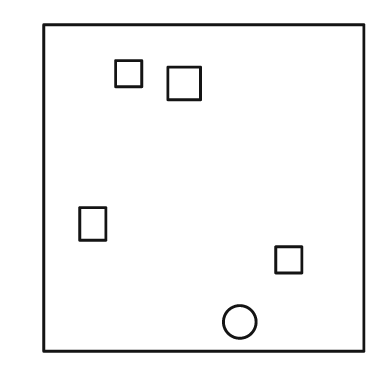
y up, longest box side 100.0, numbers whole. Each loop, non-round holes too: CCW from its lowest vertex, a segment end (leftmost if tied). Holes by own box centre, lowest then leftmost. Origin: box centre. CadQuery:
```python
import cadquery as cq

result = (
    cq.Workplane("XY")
    .moveTo(-49.0, -50.0)
    .lineTo(49.0, -50.0)
    .lineTo(49.0, 50.0)
    .lineTo(-49.0, 50.0)
    .close()
    .moveTo(11.0, -41.0)
    .circle(5.0)
    .moveTo(22.0, -26.0)
    .lineTo(30.0, -26.0)
    .lineTo(30.0, -18.0)
    .lineTo(22.0, -18.0)
    .close()
    .moveTo(-38.0, -16.0)
    .lineTo(-30.0, -16.0)
    .lineTo(-30.0, -6.0)
    .lineTo(-38.0, -6.0)
    .close()
    .moveTo(-11.0, 27.0)
    .lineTo(-1.0, 27.0)
    .lineTo(-1.0, 37.0)
    .lineTo(-11.0, 37.0)
    .close()
    .moveTo(-27.0, 31.0)
    .lineTo(-19.0, 31.0)
    .lineTo(-19.0, 39.0)
    .lineTo(-27.0, 39.0)
    .close()
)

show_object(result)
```